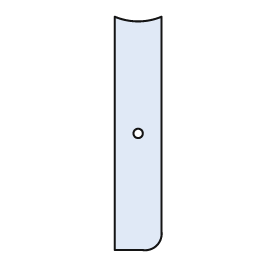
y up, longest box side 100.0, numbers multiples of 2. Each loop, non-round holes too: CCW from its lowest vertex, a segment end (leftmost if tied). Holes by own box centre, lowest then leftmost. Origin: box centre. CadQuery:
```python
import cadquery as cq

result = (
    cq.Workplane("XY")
    .moveTo(-10.0, -50.0)
    .lineTo(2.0, -50.0)
    .threePointArc((8.0, -48.0), (10.0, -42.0))
    .lineTo(10.0, 50.0)
    .threePointArc((0.0, 48.0), (-10.0, 50.0))
    .close()
    .moveTo(0.0, 0.0)
    .circle(2.0)
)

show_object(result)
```